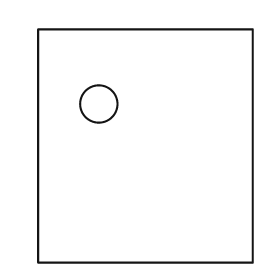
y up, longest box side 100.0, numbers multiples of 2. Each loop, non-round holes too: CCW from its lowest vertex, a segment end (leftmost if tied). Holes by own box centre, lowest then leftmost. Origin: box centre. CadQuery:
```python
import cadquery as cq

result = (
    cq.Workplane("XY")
    .moveTo(-46.0, -50.0)
    .lineTo(46.0, -50.0)
    .lineTo(46.0, 50.0)
    .lineTo(-46.0, 50.0)
    .close()
    .moveTo(-20.0, 18.0)
    .circle(8.0)
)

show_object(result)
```